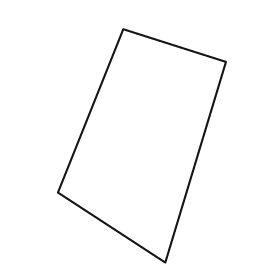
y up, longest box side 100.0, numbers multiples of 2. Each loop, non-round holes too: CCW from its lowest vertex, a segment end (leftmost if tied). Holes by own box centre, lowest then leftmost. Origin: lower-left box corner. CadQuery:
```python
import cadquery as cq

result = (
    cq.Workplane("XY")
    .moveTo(46.0, 0.0)
    .lineTo(72.0, 86.0)
    .lineTo(28.0, 100.0)
    .lineTo(0.0, 30.0)
    .close()
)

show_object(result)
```